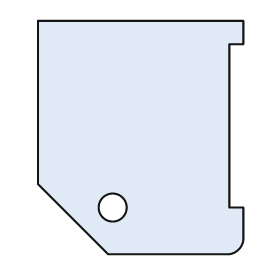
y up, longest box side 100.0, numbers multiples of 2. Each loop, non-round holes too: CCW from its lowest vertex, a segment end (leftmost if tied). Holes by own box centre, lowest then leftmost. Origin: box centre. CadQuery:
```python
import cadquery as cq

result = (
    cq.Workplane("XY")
    .moveTo(-14.0, -50.0)
    .lineTo(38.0, -50.0)
    .threePointArc((42.0, -48.0), (44.0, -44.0))
    .lineTo(44.0, -30.0)
    .lineTo(38.0, -30.0)
    .lineTo(38.0, 40.0)
    .lineTo(44.0, 40.0)
    .lineTo(44.0, 50.0)
    .lineTo(-44.0, 50.0)
    .lineTo(-44.0, -20.0)
    .close()
    .moveTo(-12.0, -30.0)
    .circle(6.0)
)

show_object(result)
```